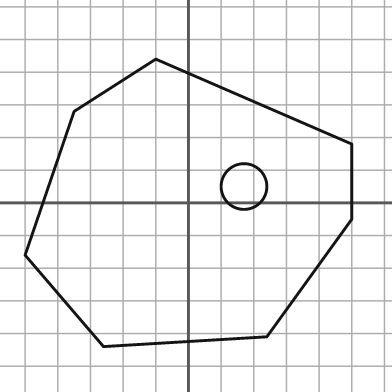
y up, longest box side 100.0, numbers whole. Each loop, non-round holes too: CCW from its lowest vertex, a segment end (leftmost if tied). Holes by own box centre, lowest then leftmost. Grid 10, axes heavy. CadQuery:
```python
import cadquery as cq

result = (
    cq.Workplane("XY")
    .moveTo(-26.0, -44.0)
    .lineTo(24.0, -41.0)
    .lineTo(50.0, -5.0)
    .lineTo(50.0, 18.0)
    .lineTo(-10.0, 44.0)
    .lineTo(-35.0, 28.0)
    .lineTo(-50.0, -16.0)
    .close()
    .moveTo(17.0, 5.0)
    .circle(7.0)
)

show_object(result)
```